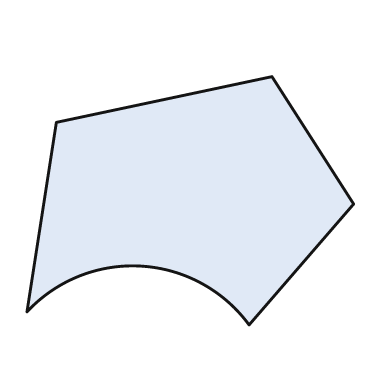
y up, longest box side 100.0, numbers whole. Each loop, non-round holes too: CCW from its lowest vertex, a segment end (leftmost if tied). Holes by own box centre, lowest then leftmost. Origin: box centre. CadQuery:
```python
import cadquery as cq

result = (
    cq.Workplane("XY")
    .moveTo(18.0, -38.0)
    .lineTo(50.0, -1.0)
    .lineTo(25.0, 38.0)
    .lineTo(-41.0, 24.0)
    .lineTo(-50.0, -34.0)
    .threePointArc((-15.0, -20.0), (18.0, -38.0))
    .close()
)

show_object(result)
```